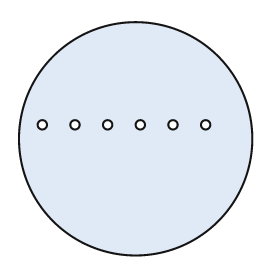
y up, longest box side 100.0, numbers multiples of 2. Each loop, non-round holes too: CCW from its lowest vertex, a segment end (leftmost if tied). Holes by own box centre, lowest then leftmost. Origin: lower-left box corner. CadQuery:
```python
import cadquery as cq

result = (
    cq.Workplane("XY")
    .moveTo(50.0, 50.0)
    .circle(50.0)
    .moveTo(10.0, 56.0)
    .circle(2.0)
    .moveTo(24.0, 56.0)
    .circle(2.0)
    .moveTo(38.0, 56.0)
    .circle(2.0)
    .moveTo(52.0, 56.0)
    .circle(2.0)
    .moveTo(66.0, 56.0)
    .circle(2.0)
    .moveTo(80.0, 56.0)
    .circle(2.0)
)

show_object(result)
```